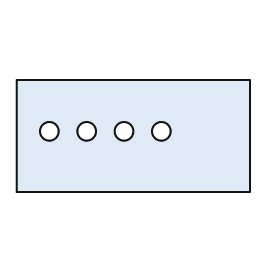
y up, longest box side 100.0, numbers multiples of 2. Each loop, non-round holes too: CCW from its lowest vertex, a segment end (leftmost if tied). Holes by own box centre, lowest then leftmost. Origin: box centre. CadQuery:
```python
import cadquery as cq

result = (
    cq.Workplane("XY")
    .moveTo(-50.0, -24.0)
    .lineTo(50.0, -24.0)
    .lineTo(50.0, 24.0)
    .lineTo(-50.0, 24.0)
    .close()
    .moveTo(-36.0, 2.0)
    .circle(4.0)
    .moveTo(-20.0, 2.0)
    .circle(4.0)
    .moveTo(-4.0, 2.0)
    .circle(4.0)
    .moveTo(12.0, 2.0)
    .circle(4.0)
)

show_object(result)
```